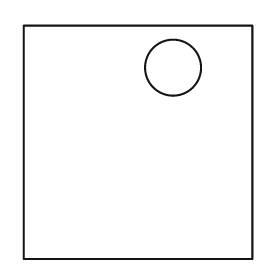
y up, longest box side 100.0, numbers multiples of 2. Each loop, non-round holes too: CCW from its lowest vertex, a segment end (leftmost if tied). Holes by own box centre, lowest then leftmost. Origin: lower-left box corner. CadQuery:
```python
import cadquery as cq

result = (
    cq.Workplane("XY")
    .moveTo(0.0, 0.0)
    .lineTo(98.0, 0.0)
    .lineTo(98.0, 100.0)
    .lineTo(0.0, 100.0)
    .close()
    .moveTo(64.0, 82.0)
    .circle(12.0)
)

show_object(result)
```